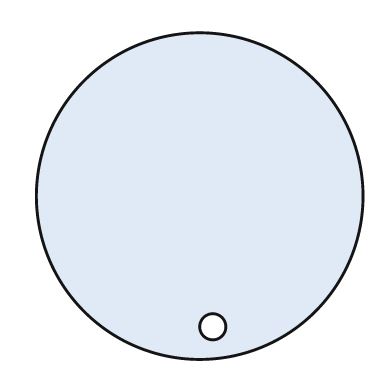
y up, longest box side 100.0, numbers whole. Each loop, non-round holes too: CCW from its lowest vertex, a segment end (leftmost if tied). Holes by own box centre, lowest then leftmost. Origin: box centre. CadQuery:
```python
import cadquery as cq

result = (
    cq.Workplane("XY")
    .moveTo(0.0, 0.0)
    .circle(50.0)
    .moveTo(4.0, -40.0)
    .circle(4.0)
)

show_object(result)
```